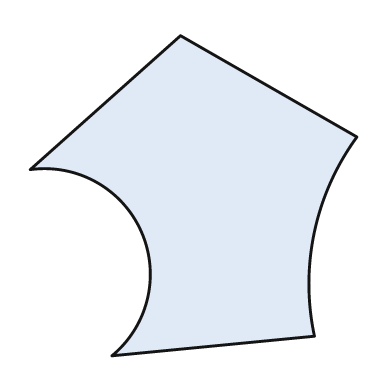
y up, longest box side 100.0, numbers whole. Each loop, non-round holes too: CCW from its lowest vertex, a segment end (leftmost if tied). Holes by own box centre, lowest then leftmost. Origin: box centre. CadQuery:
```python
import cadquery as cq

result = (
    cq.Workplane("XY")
    .moveTo(-25.0, -49.0)
    .lineTo(37.0, -43.0)
    .threePointArc((37.0, -11.0), (50.0, 18.0))
    .lineTo(-4.0, 49.0)
    .lineTo(-50.0, 8.0)
    .threePointArc((-16.0, -11.0), (-25.0, -49.0))
    .close()
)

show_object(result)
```